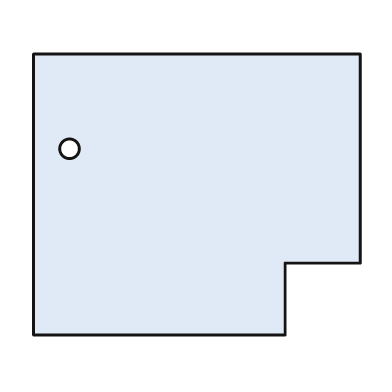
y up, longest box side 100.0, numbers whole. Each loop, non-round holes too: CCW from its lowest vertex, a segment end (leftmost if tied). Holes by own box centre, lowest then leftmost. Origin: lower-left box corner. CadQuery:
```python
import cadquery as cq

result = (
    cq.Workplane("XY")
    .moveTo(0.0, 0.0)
    .lineTo(77.0, 0.0)
    .lineTo(77.0, 22.0)
    .lineTo(100.0, 22.0)
    .lineTo(100.0, 86.0)
    .lineTo(0.0, 86.0)
    .close()
    .moveTo(11.0, 57.0)
    .circle(3.0)
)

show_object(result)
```